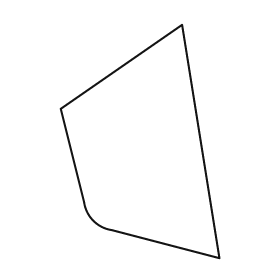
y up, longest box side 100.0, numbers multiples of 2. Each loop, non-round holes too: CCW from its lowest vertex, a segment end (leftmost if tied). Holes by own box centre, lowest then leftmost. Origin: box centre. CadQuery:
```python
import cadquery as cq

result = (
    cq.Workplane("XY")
    .moveTo(34.0, -50.0)
    .lineTo(18.0, 50.0)
    .lineTo(-34.0, 14.0)
    .lineTo(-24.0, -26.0)
    .threePointArc((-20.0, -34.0), (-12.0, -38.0))
    .close()
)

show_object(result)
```